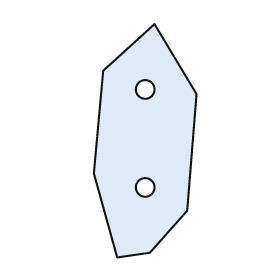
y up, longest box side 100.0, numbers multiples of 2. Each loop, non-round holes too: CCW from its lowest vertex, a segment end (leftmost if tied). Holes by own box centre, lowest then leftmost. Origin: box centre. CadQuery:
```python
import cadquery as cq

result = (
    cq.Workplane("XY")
    .moveTo(-12.0, -50.0)
    .lineTo(2.0, -48.0)
    .lineTo(18.0, -30.0)
    .lineTo(22.0, 20.0)
    .lineTo(4.0, 50.0)
    .lineTo(-18.0, 30.0)
    .lineTo(-22.0, -14.0)
    .close()
    .moveTo(0.0, -20.0)
    .circle(4.0)
    .moveTo(0.0, 22.0)
    .circle(4.0)
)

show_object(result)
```